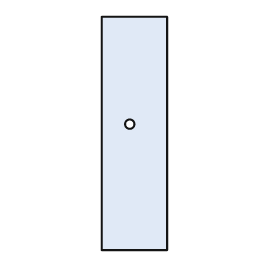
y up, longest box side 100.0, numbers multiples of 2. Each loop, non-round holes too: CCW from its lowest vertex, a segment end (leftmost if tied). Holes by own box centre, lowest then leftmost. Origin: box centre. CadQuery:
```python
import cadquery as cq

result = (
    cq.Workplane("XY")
    .moveTo(-14.0, -50.0)
    .lineTo(14.0, -50.0)
    .lineTo(14.0, 50.0)
    .lineTo(-14.0, 50.0)
    .close()
    .moveTo(-2.0, 4.0)
    .circle(2.0)
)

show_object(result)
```